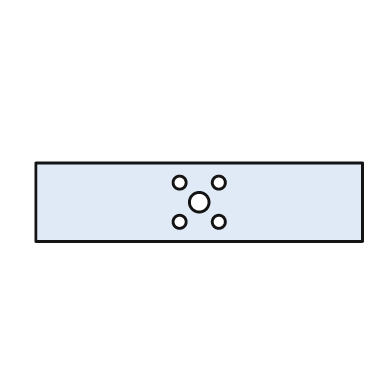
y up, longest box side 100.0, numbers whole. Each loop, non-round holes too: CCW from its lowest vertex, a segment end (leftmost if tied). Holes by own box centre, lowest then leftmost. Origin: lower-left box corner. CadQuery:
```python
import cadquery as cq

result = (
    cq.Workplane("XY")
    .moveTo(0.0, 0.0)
    .lineTo(100.0, 0.0)
    .lineTo(100.0, 24.0)
    .lineTo(0.0, 24.0)
    .close()
    .moveTo(44.0, 6.0)
    .circle(2.0)
    .moveTo(56.0, 6.0)
    .circle(2.0)
    .moveTo(50.0, 12.0)
    .circle(3.0)
    .moveTo(44.0, 18.0)
    .circle(2.0)
    .moveTo(56.0, 18.0)
    .circle(2.0)
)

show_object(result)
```